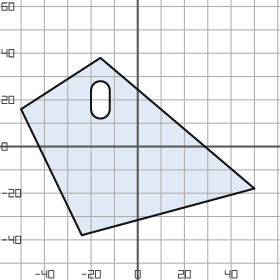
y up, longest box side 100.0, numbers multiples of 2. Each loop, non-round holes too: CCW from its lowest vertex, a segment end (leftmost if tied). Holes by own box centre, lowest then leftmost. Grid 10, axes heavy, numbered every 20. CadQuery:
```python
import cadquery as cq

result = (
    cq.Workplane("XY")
    .moveTo(-24.0, -38.0)
    .lineTo(50.0, -18.0)
    .lineTo(-16.0, 38.0)
    .lineTo(-50.0, 16.0)
    .close()
    .moveTo(-20.0, 16.0)
    .threePointArc((-16.0, 12.0), (-12.0, 16.0))
    .lineTo(-12.0, 24.0)
    .threePointArc((-16.0, 28.0), (-20.0, 24.0))
    .close()
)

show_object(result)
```